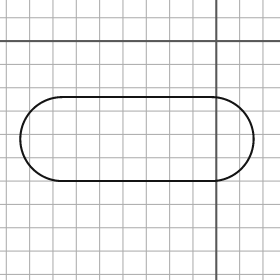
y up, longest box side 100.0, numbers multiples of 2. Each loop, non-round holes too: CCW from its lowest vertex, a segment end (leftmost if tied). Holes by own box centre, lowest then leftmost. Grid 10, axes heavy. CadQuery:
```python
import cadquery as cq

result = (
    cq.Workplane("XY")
    .moveTo(-66.0, -60.0)
    .lineTo(-2.0, -60.0)
    .threePointArc((16.0, -42.0), (-2.0, -24.0))
    .lineTo(-66.0, -24.0)
    .threePointArc((-84.0, -42.0), (-66.0, -60.0))
    .close()
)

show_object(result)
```